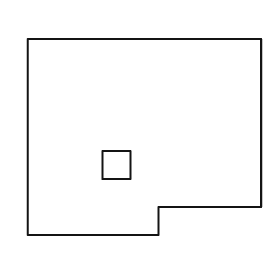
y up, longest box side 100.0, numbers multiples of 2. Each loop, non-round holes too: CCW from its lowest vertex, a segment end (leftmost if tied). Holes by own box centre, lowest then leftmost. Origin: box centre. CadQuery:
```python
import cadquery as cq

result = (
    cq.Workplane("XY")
    .moveTo(-50.0, -42.0)
    .lineTo(6.0, -42.0)
    .lineTo(6.0, -30.0)
    .lineTo(50.0, -30.0)
    .lineTo(50.0, 42.0)
    .lineTo(-50.0, 42.0)
    .close()
    .moveTo(-18.0, -18.0)
    .lineTo(-6.0, -18.0)
    .lineTo(-6.0, -6.0)
    .lineTo(-18.0, -6.0)
    .close()
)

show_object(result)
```